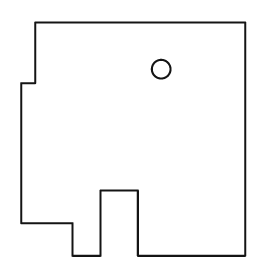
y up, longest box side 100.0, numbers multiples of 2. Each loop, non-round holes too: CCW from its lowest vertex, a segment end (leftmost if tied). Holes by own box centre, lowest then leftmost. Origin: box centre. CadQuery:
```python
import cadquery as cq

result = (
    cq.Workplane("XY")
    .moveTo(-26.0, -50.0)
    .lineTo(-14.0, -50.0)
    .lineTo(-14.0, -22.0)
    .lineTo(2.0, -22.0)
    .lineTo(2.0, -50.0)
    .lineTo(48.0, -50.0)
    .lineTo(48.0, 50.0)
    .lineTo(-42.0, 50.0)
    .lineTo(-42.0, 24.0)
    .lineTo(-48.0, 24.0)
    .lineTo(-48.0, -36.0)
    .lineTo(-26.0, -36.0)
    .close()
    .moveTo(12.0, 30.0)
    .circle(4.0)
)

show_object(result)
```